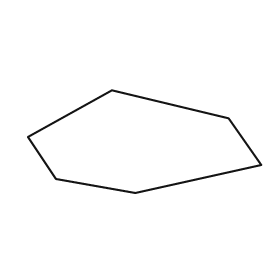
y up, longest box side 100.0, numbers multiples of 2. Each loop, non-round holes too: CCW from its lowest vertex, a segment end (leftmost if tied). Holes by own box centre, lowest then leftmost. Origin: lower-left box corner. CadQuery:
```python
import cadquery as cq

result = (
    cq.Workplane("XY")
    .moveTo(46.0, 0.0)
    .lineTo(100.0, 12.0)
    .lineTo(86.0, 32.0)
    .lineTo(36.0, 44.0)
    .lineTo(0.0, 24.0)
    .lineTo(12.0, 6.0)
    .close()
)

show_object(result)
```